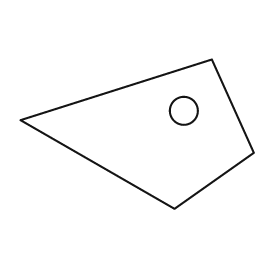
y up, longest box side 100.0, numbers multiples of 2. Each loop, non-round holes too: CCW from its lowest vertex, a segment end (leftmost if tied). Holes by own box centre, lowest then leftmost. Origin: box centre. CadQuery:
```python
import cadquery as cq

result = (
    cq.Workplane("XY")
    .moveTo(16.0, -32.0)
    .lineTo(50.0, -8.0)
    .lineTo(32.0, 32.0)
    .lineTo(-50.0, 6.0)
    .close()
    .moveTo(20.0, 10.0)
    .circle(6.0)
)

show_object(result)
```